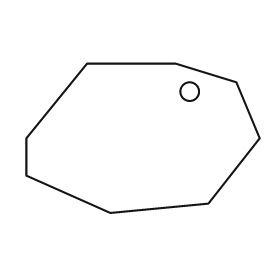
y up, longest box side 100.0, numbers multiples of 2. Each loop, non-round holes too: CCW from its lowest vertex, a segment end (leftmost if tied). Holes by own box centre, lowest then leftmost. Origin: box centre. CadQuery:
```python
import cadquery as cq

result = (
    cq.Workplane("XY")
    .moveTo(-14.0, -32.0)
    .lineTo(28.0, -28.0)
    .lineTo(50.0, 0.0)
    .lineTo(40.0, 24.0)
    .lineTo(14.0, 32.0)
    .lineTo(-24.0, 32.0)
    .lineTo(-50.0, 0.0)
    .lineTo(-50.0, -16.0)
    .close()
    .moveTo(20.0, 20.0)
    .circle(4.0)
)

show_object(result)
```